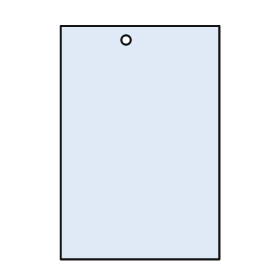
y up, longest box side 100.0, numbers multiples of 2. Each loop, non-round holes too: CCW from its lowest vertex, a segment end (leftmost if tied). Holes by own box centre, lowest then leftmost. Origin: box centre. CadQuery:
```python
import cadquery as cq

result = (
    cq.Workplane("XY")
    .moveTo(-34.0, -50.0)
    .lineTo(34.0, -50.0)
    .lineTo(34.0, 50.0)
    .lineTo(-34.0, 50.0)
    .close()
    .moveTo(-6.0, 44.0)
    .circle(2.0)
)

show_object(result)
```